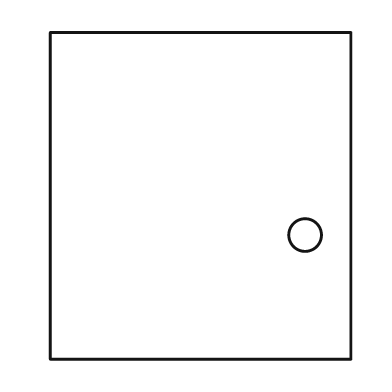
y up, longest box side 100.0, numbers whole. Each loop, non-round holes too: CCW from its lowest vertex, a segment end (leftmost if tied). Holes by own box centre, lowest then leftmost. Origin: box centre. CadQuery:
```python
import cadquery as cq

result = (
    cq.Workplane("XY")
    .moveTo(-46.0, -50.0)
    .lineTo(46.0, -50.0)
    .lineTo(46.0, 50.0)
    .lineTo(-46.0, 50.0)
    .close()
    .moveTo(32.0, -12.0)
    .circle(5.0)
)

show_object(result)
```